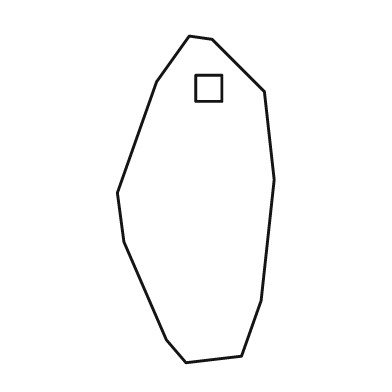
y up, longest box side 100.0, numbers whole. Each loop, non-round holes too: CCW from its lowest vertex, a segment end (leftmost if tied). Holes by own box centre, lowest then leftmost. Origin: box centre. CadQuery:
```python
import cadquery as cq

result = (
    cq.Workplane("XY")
    .moveTo(-3.0, -50.0)
    .lineTo(14.0, -48.0)
    .lineTo(20.0, -31.0)
    .lineTo(24.0, 6.0)
    .lineTo(21.0, 33.0)
    .lineTo(5.0, 49.0)
    .lineTo(-2.0, 50.0)
    .lineTo(-12.0, 36.0)
    .lineTo(-24.0, 2.0)
    .lineTo(-22.0, -13.0)
    .lineTo(-9.0, -43.0)
    .close()
    .moveTo(0.0, 30.0)
    .lineTo(8.0, 30.0)
    .lineTo(8.0, 38.0)
    .lineTo(0.0, 38.0)
    .close()
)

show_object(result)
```